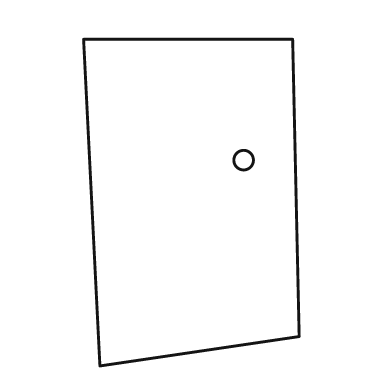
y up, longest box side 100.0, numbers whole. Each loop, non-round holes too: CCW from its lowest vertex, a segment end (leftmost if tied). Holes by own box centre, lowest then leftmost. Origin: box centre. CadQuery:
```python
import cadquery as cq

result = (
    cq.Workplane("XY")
    .moveTo(-28.0, -50.0)
    .lineTo(33.0, -41.0)
    .lineTo(31.0, 50.0)
    .lineTo(-33.0, 50.0)
    .close()
    .moveTo(16.0, 13.0)
    .circle(3.0)
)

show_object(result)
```